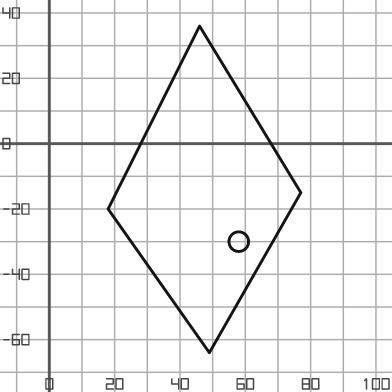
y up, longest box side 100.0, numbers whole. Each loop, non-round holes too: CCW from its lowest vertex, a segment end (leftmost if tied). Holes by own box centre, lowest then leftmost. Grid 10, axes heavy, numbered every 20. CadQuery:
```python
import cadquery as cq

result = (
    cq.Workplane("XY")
    .moveTo(49.0, -64.0)
    .lineTo(77.0, -15.0)
    .lineTo(46.0, 36.0)
    .lineTo(18.0, -20.0)
    .close()
    .moveTo(58.0, -30.0)
    .circle(3.0)
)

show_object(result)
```